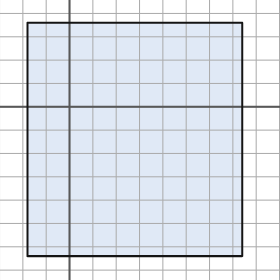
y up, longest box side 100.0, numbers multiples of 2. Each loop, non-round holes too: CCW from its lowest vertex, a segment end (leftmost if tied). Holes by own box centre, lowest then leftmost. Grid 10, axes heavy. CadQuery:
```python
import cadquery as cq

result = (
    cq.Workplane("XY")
    .moveTo(-18.0, -64.0)
    .lineTo(74.0, -64.0)
    .lineTo(74.0, 36.0)
    .lineTo(-18.0, 36.0)
    .close()
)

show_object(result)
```